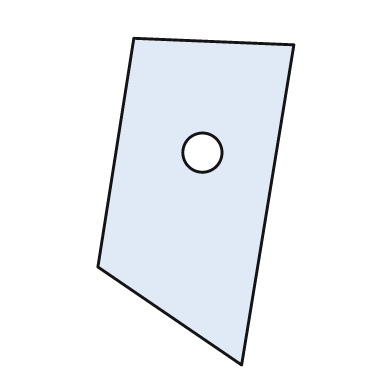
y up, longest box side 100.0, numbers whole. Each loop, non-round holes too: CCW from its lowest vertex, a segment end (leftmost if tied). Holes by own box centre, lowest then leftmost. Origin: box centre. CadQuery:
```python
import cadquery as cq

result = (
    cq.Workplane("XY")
    .moveTo(14.0, -50.0)
    .lineTo(30.0, 48.0)
    .lineTo(-19.0, 50.0)
    .lineTo(-30.0, -20.0)
    .close()
    .moveTo(2.0, 15.0)
    .circle(6.0)
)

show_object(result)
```